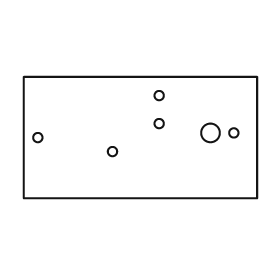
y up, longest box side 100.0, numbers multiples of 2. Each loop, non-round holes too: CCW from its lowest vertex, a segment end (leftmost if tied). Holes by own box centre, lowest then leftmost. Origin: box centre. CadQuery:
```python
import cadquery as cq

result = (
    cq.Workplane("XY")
    .moveTo(-50.0, -26.0)
    .lineTo(50.0, -26.0)
    .lineTo(50.0, 26.0)
    .lineTo(-50.0, 26.0)
    .close()
    .moveTo(-12.0, -6.0)
    .circle(2.0)
    .moveTo(-44.0, 0.0)
    .circle(2.0)
    .moveTo(30.0, 2.0)
    .circle(4.0)
    .moveTo(40.0, 2.0)
    .circle(2.0)
    .moveTo(8.0, 6.0)
    .circle(2.0)
    .moveTo(8.0, 18.0)
    .circle(2.0)
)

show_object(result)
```